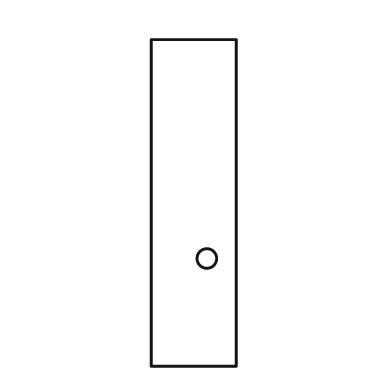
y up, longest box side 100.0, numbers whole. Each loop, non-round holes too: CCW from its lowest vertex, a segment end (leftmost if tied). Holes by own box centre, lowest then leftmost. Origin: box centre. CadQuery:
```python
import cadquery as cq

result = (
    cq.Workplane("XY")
    .moveTo(-13.0, -50.0)
    .lineTo(13.0, -50.0)
    .lineTo(13.0, 50.0)
    .lineTo(-13.0, 50.0)
    .close()
    .moveTo(4.0, -17.0)
    .circle(3.0)
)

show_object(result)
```